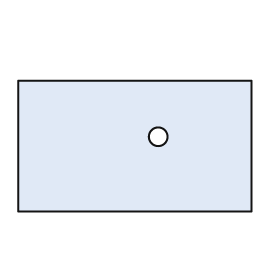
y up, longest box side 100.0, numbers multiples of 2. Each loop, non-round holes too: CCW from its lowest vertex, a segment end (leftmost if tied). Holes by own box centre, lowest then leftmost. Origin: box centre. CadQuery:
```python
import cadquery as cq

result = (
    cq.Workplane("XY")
    .moveTo(-50.0, -28.0)
    .lineTo(50.0, -28.0)
    .lineTo(50.0, 28.0)
    .lineTo(-50.0, 28.0)
    .close()
    .moveTo(10.0, 4.0)
    .circle(4.0)
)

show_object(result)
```